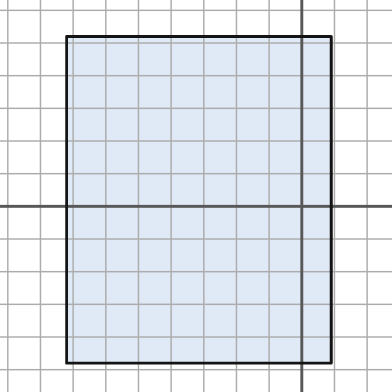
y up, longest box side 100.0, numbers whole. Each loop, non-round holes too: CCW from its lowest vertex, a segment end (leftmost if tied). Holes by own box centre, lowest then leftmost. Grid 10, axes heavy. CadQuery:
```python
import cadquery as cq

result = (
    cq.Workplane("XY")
    .moveTo(-72.0, -48.0)
    .lineTo(9.0, -48.0)
    .lineTo(9.0, 52.0)
    .lineTo(-72.0, 52.0)
    .close()
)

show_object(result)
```